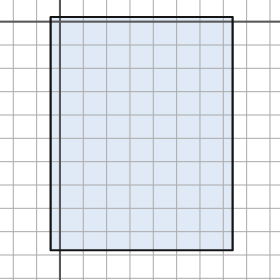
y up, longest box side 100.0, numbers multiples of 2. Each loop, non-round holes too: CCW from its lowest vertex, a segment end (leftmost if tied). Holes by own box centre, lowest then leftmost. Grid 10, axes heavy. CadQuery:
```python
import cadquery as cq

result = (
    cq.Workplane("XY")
    .moveTo(-4.0, -98.0)
    .lineTo(74.0, -98.0)
    .lineTo(74.0, 2.0)
    .lineTo(-4.0, 2.0)
    .close()
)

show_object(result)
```